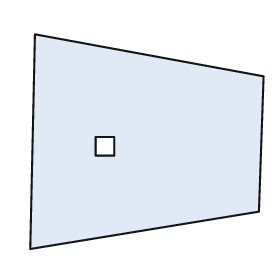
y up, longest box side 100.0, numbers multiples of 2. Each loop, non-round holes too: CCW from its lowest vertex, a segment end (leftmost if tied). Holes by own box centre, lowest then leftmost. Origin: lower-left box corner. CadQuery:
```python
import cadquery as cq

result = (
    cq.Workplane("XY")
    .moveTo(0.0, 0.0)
    .lineTo(98.0, 16.0)
    .lineTo(100.0, 74.0)
    .lineTo(2.0, 92.0)
    .close()
    .moveTo(28.0, 40.0)
    .lineTo(36.0, 40.0)
    .lineTo(36.0, 48.0)
    .lineTo(28.0, 48.0)
    .close()
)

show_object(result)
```